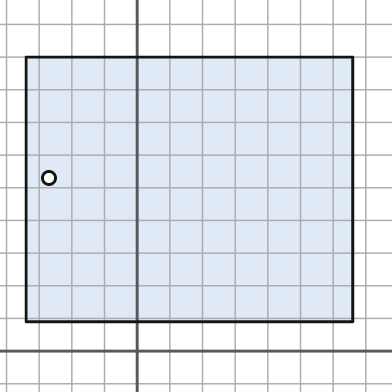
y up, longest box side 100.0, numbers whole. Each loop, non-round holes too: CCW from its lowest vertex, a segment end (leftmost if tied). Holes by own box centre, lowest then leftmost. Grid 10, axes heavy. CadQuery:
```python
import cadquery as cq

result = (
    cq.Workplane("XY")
    .moveTo(-34.0, 9.0)
    .lineTo(66.0, 9.0)
    .lineTo(66.0, 90.0)
    .lineTo(-34.0, 90.0)
    .close()
    .moveTo(-27.0, 53.0)
    .circle(2.0)
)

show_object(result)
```